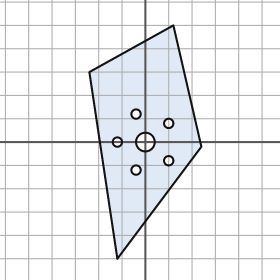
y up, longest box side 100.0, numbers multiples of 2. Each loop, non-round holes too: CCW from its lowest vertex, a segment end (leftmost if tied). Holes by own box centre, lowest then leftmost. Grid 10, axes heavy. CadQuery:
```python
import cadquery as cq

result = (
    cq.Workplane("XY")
    .moveTo(-12.0, -50.0)
    .lineTo(24.0, -2.0)
    .lineTo(12.0, 50.0)
    .lineTo(-24.0, 30.0)
    .close()
    .moveTo(-4.0, -12.0)
    .circle(2.0)
    .moveTo(10.0, -8.0)
    .circle(2.0)
    .moveTo(-12.0, 0.0)
    .circle(2.0)
    .moveTo(0.0, 0.0)
    .circle(4.0)
    .moveTo(10.0, 8.0)
    .circle(2.0)
    .moveTo(-4.0, 12.0)
    .circle(2.0)
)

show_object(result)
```